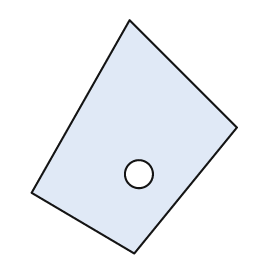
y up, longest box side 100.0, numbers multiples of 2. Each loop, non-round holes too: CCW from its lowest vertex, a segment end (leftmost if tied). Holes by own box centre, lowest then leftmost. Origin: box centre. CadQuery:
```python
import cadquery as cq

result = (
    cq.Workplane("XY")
    .moveTo(0.0, -50.0)
    .lineTo(44.0, 4.0)
    .lineTo(-2.0, 50.0)
    .lineTo(-44.0, -24.0)
    .close()
    .moveTo(2.0, -16.0)
    .circle(6.0)
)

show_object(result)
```